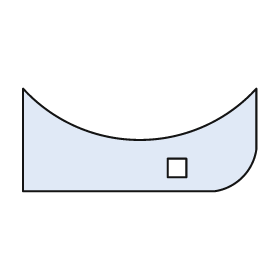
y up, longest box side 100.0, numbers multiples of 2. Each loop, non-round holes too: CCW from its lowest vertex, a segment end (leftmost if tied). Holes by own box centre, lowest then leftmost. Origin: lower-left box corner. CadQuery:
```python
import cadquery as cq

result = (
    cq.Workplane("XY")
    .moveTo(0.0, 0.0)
    .lineTo(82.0, 0.0)
    .threePointArc((94.0, 6.0), (100.0, 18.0))
    .lineTo(100.0, 44.0)
    .threePointArc((50.0, 22.0), (0.0, 44.0))
    .close()
    .moveTo(62.0, 6.0)
    .lineTo(70.0, 6.0)
    .lineTo(70.0, 14.0)
    .lineTo(62.0, 14.0)
    .close()
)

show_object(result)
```